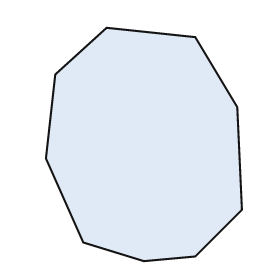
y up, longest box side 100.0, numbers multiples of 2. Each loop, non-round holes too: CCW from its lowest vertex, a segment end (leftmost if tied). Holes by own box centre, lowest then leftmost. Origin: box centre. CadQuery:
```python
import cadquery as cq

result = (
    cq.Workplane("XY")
    .moveTo(0.0, -50.0)
    .lineTo(22.0, -48.0)
    .lineTo(42.0, -28.0)
    .lineTo(40.0, 16.0)
    .lineTo(22.0, 46.0)
    .lineTo(-16.0, 50.0)
    .lineTo(-38.0, 30.0)
    .lineTo(-42.0, -6.0)
    .lineTo(-26.0, -42.0)
    .close()
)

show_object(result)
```